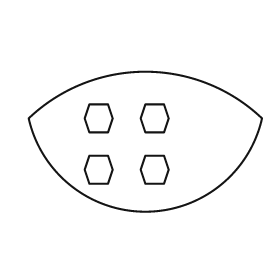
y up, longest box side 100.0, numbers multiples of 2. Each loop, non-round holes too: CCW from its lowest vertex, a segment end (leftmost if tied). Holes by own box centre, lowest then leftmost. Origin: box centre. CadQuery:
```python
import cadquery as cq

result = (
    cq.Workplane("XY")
    .moveTo(-50.0, 10.0)
    .threePointArc((0.0, -30.0), (50.0, 10.0))
    .threePointArc((0.0, 30.0), (-50.0, 10.0))
    .close()
    .moveTo(-24.0, -18.0)
    .lineTo(-16.0, -18.0)
    .lineTo(-14.0, -12.0)
    .lineTo(-16.0, -6.0)
    .lineTo(-24.0, -6.0)
    .lineTo(-26.0, -12.0)
    .close()
    .moveTo(0.0, -18.0)
    .lineTo(8.0, -18.0)
    .lineTo(10.0, -12.0)
    .lineTo(8.0, -6.0)
    .lineTo(0.0, -6.0)
    .lineTo(-2.0, -12.0)
    .close()
    .moveTo(-24.0, 4.0)
    .lineTo(-16.0, 4.0)
    .lineTo(-14.0, 10.0)
    .lineTo(-16.0, 16.0)
    .lineTo(-24.0, 16.0)
    .lineTo(-26.0, 10.0)
    .close()
    .moveTo(0.0, 4.0)
    .lineTo(8.0, 4.0)
    .lineTo(10.0, 10.0)
    .lineTo(8.0, 16.0)
    .lineTo(0.0, 16.0)
    .lineTo(-2.0, 10.0)
    .close()
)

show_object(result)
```